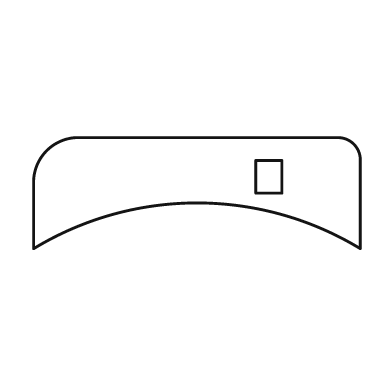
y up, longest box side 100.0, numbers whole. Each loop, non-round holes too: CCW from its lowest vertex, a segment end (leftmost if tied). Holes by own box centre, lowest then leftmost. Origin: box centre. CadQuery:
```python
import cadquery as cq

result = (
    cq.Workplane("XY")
    .moveTo(-50.0, -17.0)
    .threePointArc((0.0, -3.0), (50.0, -17.0))
    .lineTo(50.0, 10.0)
    .threePointArc((48.0, 15.0), (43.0, 17.0))
    .lineTo(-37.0, 17.0)
    .threePointArc((-46.0, 13.0), (-50.0, 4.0))
    .close()
    .moveTo(18.0, 0.0)
    .lineTo(26.0, 0.0)
    .lineTo(26.0, 10.0)
    .lineTo(18.0, 10.0)
    .close()
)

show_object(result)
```